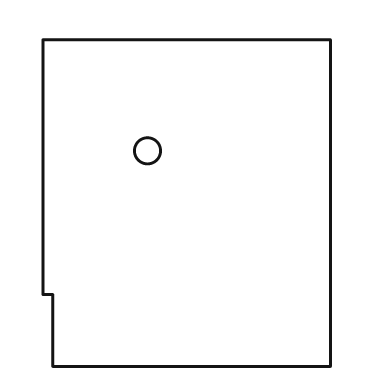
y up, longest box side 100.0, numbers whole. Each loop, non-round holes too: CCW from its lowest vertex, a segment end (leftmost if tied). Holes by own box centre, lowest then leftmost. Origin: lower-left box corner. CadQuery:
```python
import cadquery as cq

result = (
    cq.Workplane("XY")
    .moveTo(3.0, 0.0)
    .lineTo(88.0, 0.0)
    .lineTo(88.0, 100.0)
    .lineTo(0.0, 100.0)
    .lineTo(0.0, 22.0)
    .lineTo(3.0, 22.0)
    .close()
    .moveTo(32.0, 66.0)
    .circle(4.0)
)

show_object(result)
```